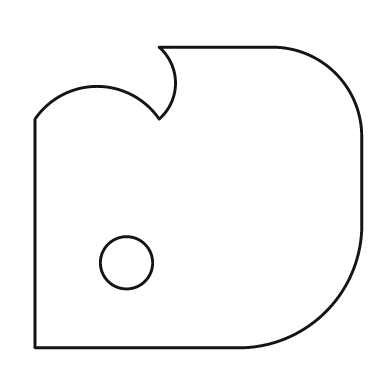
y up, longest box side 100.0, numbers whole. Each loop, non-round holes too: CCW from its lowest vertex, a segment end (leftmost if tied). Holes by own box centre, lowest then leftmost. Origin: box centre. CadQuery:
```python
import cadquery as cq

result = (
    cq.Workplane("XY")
    .moveTo(-50.0, -46.0)
    .lineTo(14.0, -46.0)
    .threePointArc((39.0, -35.0), (50.0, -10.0))
    .lineTo(50.0, 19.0)
    .threePointArc((42.0, 38.0), (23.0, 46.0))
    .lineTo(-12.0, 46.0)
    .threePointArc((-7.0, 35.0), (-12.0, 24.0))
    .threePointArc((-31.0, 34.0), (-50.0, 24.0))
    .close()
    .moveTo(-22.0, -20.0)
    .circle(8.0)
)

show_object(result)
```